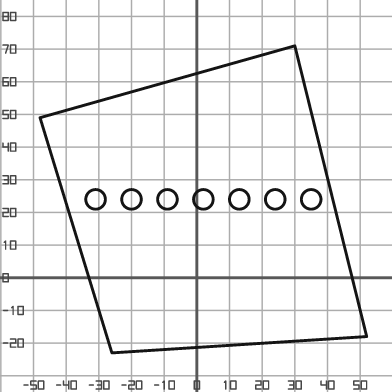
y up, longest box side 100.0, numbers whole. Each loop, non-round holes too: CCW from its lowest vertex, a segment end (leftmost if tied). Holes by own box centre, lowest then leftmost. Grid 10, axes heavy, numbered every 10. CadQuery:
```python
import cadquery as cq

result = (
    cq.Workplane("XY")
    .moveTo(-26.0, -23.0)
    .lineTo(52.0, -18.0)
    .lineTo(30.0, 71.0)
    .lineTo(-48.0, 49.0)
    .close()
    .moveTo(-31.0, 24.0)
    .circle(3.0)
    .moveTo(-20.0, 24.0)
    .circle(3.0)
    .moveTo(-9.0, 24.0)
    .circle(3.0)
    .moveTo(2.0, 24.0)
    .circle(3.0)
    .moveTo(13.0, 24.0)
    .circle(3.0)
    .moveTo(24.0, 24.0)
    .circle(3.0)
    .moveTo(35.0, 24.0)
    .circle(3.0)
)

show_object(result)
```